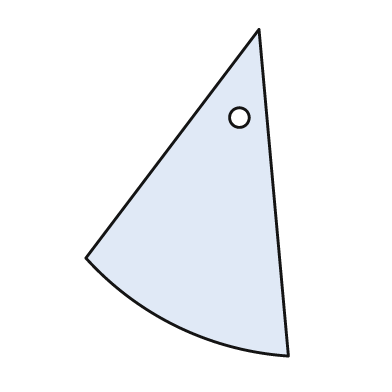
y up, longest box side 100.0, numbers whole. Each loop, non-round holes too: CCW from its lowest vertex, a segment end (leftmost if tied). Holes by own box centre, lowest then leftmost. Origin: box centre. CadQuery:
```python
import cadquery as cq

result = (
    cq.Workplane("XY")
    .moveTo(31.0, -50.0)
    .lineTo(22.0, 50.0)
    .lineTo(-31.0, -20.0)
    .threePointArc((-3.0, -41.0), (31.0, -50.0))
    .close()
    .moveTo(16.0, 23.0)
    .circle(3.0)
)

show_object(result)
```